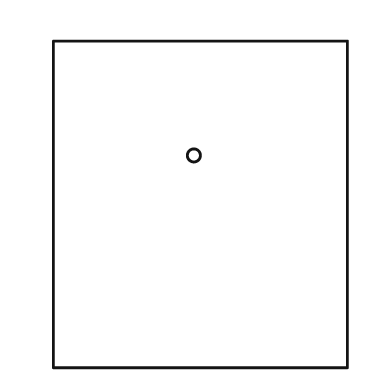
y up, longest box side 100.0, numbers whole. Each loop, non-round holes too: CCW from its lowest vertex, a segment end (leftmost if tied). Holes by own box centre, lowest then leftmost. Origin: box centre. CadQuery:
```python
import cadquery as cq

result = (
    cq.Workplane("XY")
    .moveTo(-45.0, -50.0)
    .lineTo(45.0, -50.0)
    .lineTo(45.0, 50.0)
    .lineTo(-45.0, 50.0)
    .close()
    .moveTo(-2.0, 15.0)
    .circle(2.0)
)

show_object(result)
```